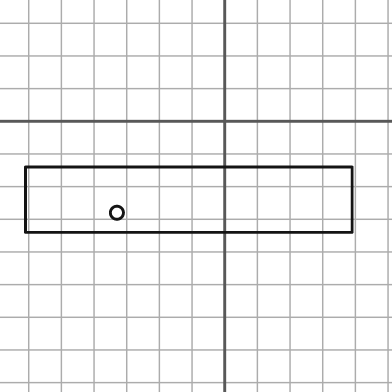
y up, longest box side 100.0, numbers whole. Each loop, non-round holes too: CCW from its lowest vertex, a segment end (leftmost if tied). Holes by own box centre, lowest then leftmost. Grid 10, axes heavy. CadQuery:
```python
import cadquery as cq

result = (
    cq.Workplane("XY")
    .moveTo(-61.0, -34.0)
    .lineTo(39.0, -34.0)
    .lineTo(39.0, -14.0)
    .lineTo(-61.0, -14.0)
    .close()
    .moveTo(-33.0, -28.0)
    .circle(2.0)
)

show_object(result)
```